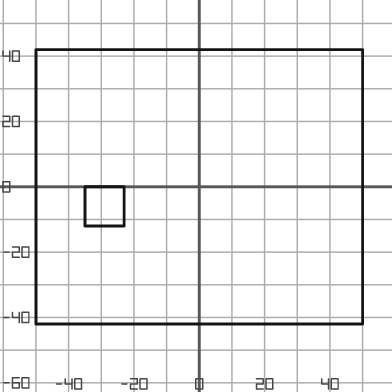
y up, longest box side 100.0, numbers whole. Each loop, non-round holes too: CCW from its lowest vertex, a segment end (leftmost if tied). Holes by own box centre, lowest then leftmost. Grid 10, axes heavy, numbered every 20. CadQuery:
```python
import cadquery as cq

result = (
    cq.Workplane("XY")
    .moveTo(-50.0, -42.0)
    .lineTo(50.0, -42.0)
    .lineTo(50.0, 42.0)
    .lineTo(-50.0, 42.0)
    .close()
    .moveTo(-35.0, -12.0)
    .lineTo(-23.0, -12.0)
    .lineTo(-23.0, 0.0)
    .lineTo(-35.0, 0.0)
    .close()
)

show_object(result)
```